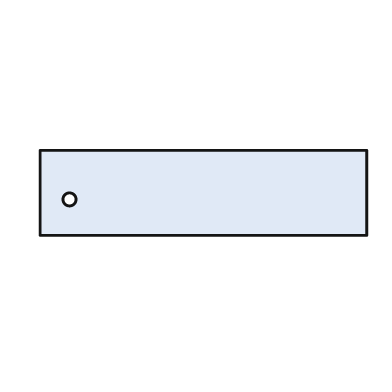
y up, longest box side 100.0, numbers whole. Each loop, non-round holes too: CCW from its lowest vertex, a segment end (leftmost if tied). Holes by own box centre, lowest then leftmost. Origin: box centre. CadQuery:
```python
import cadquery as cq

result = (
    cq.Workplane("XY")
    .moveTo(-50.0, -13.0)
    .lineTo(50.0, -13.0)
    .lineTo(50.0, 13.0)
    .lineTo(-50.0, 13.0)
    .close()
    .moveTo(-41.0, -2.0)
    .circle(2.0)
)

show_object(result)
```